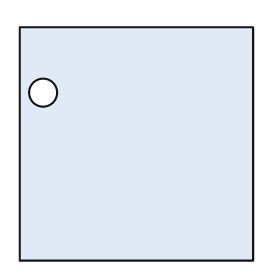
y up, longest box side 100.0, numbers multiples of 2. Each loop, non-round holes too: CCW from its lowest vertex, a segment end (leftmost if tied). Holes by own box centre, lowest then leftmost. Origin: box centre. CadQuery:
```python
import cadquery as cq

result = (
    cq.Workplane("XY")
    .moveTo(-50.0, -50.0)
    .lineTo(50.0, -50.0)
    .lineTo(50.0, 50.0)
    .lineTo(-50.0, 50.0)
    .close()
    .moveTo(-40.0, 22.0)
    .circle(6.0)
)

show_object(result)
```